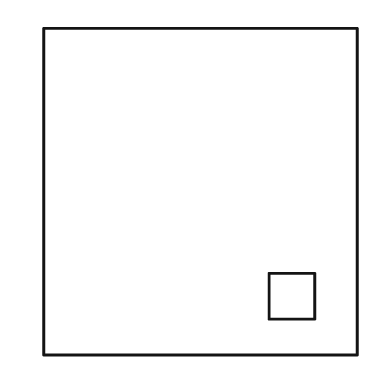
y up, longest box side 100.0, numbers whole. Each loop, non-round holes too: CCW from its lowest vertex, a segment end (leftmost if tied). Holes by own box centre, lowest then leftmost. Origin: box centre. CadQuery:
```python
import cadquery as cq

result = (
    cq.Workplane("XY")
    .moveTo(-48.0, -50.0)
    .lineTo(48.0, -50.0)
    .lineTo(48.0, 50.0)
    .lineTo(-48.0, 50.0)
    .close()
    .moveTo(21.0, -39.0)
    .lineTo(35.0, -39.0)
    .lineTo(35.0, -25.0)
    .lineTo(21.0, -25.0)
    .close()
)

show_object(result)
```